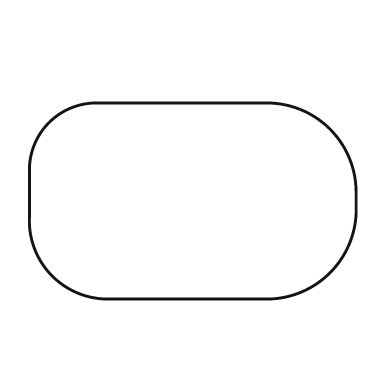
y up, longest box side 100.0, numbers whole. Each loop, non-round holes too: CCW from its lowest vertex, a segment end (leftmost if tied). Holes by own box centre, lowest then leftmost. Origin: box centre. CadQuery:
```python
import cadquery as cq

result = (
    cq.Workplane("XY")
    .moveTo(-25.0, -30.0)
    .lineTo(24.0, -30.0)
    .threePointArc((42.0, -22.0), (50.0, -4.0))
    .lineTo(50.0, 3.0)
    .threePointArc((42.0, 22.0), (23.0, 30.0))
    .lineTo(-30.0, 30.0)
    .threePointArc((-44.0, 24.0), (-50.0, 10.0))
    .lineTo(-50.0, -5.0)
    .threePointArc((-43.0, -23.0), (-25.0, -30.0))
    .close()
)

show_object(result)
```